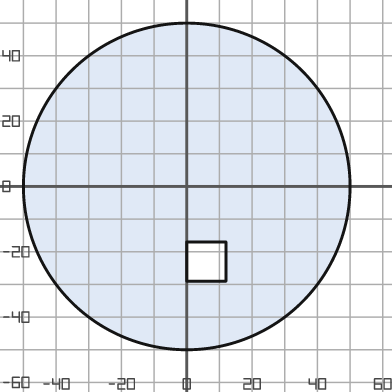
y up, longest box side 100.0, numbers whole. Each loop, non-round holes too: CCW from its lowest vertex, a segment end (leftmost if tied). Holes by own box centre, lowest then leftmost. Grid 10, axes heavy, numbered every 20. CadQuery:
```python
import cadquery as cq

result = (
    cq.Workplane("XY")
    .moveTo(0.0, 0.0)
    .circle(50.0)
    .moveTo(0.0, -29.0)
    .lineTo(12.0, -29.0)
    .lineTo(12.0, -17.0)
    .lineTo(0.0, -17.0)
    .close()
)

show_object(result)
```